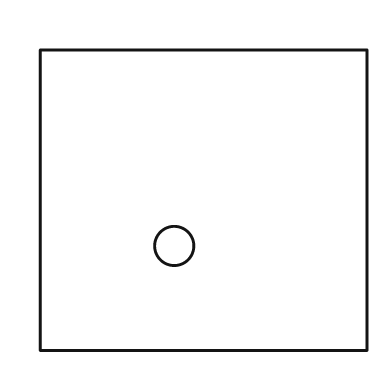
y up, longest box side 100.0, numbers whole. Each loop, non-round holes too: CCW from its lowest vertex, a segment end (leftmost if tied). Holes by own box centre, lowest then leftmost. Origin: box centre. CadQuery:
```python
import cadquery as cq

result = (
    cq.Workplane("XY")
    .moveTo(-50.0, -46.0)
    .lineTo(50.0, -46.0)
    .lineTo(50.0, 46.0)
    .lineTo(-50.0, 46.0)
    .close()
    .moveTo(-9.0, -14.0)
    .circle(6.0)
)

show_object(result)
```